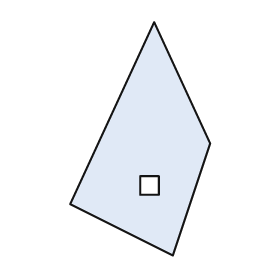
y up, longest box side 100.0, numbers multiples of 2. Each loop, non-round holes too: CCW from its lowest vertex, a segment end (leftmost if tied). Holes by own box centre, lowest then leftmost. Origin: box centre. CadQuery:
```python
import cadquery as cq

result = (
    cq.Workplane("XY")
    .moveTo(14.0, -50.0)
    .lineTo(30.0, -2.0)
    .lineTo(6.0, 50.0)
    .lineTo(-30.0, -28.0)
    .close()
    .moveTo(0.0, -24.0)
    .lineTo(8.0, -24.0)
    .lineTo(8.0, -16.0)
    .lineTo(0.0, -16.0)
    .close()
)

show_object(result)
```